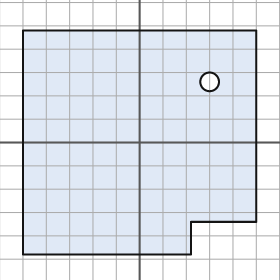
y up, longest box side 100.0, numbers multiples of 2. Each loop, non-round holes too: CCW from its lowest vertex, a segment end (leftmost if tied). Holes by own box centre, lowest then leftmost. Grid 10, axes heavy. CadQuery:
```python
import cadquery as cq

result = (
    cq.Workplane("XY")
    .moveTo(-50.0, -48.0)
    .lineTo(22.0, -48.0)
    .lineTo(22.0, -34.0)
    .lineTo(50.0, -34.0)
    .lineTo(50.0, 48.0)
    .lineTo(-50.0, 48.0)
    .close()
    .moveTo(30.0, 26.0)
    .circle(4.0)
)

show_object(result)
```